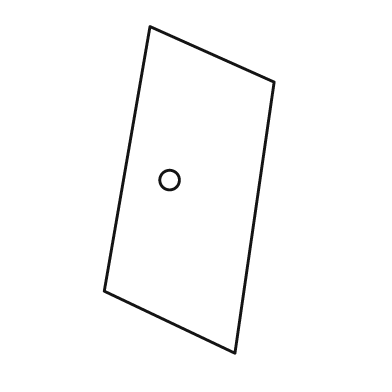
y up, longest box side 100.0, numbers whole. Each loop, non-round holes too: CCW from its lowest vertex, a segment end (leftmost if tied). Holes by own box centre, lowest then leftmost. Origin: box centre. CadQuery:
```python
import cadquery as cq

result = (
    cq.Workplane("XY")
    .moveTo(14.0, -50.0)
    .lineTo(26.0, 33.0)
    .lineTo(-12.0, 50.0)
    .lineTo(-26.0, -31.0)
    .close()
    .moveTo(-6.0, 3.0)
    .circle(3.0)
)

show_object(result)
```